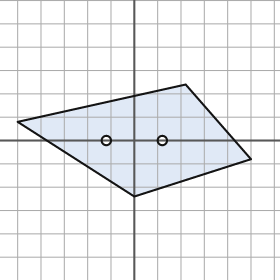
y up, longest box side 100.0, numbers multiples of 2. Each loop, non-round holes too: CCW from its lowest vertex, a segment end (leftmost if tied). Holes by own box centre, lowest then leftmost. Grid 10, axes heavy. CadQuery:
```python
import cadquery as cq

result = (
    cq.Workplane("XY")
    .moveTo(0.0, -24.0)
    .lineTo(50.0, -8.0)
    .lineTo(22.0, 24.0)
    .lineTo(-50.0, 8.0)
    .close()
    .moveTo(-12.0, 0.0)
    .circle(2.0)
    .moveTo(12.0, 0.0)
    .circle(2.0)
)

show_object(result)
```